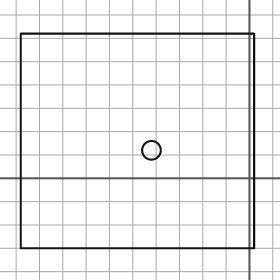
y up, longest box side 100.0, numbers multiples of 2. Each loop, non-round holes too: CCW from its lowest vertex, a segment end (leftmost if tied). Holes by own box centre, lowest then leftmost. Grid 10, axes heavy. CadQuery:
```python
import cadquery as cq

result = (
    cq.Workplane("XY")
    .moveTo(-98.0, -30.0)
    .lineTo(2.0, -30.0)
    .lineTo(2.0, 62.0)
    .lineTo(-98.0, 62.0)
    .close()
    .moveTo(-42.0, 12.0)
    .circle(4.0)
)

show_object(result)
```